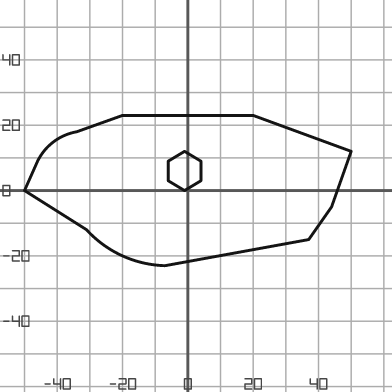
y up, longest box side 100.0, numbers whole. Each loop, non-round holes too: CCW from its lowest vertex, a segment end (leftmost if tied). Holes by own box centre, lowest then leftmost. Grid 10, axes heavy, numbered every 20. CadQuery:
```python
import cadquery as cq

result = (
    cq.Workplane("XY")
    .moveTo(-7.0, -23.0)
    .lineTo(37.0, -15.0)
    .lineTo(44.0, -5.0)
    .lineTo(50.0, 12.0)
    .lineTo(20.0, 23.0)
    .lineTo(-20.0, 23.0)
    .lineTo(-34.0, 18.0)
    .threePointArc((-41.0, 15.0), (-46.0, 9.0))
    .lineTo(-50.0, 0.0)
    .lineTo(-31.0, -12.0)
    .threePointArc((-20.0, -20.0), (-7.0, -23.0))
    .close()
    .moveTo(-1.0, 0.0)
    .lineTo(4.0, 3.0)
    .lineTo(4.0, 9.0)
    .lineTo(-1.0, 12.0)
    .lineTo(-6.0, 9.0)
    .lineTo(-6.0, 3.0)
    .close()
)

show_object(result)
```